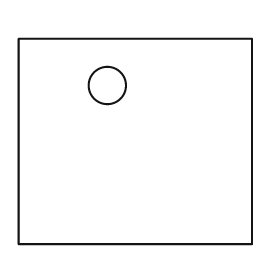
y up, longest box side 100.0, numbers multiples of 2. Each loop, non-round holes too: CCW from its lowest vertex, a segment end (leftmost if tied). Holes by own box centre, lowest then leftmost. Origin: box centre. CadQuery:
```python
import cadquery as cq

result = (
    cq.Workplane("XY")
    .moveTo(-50.0, -44.0)
    .lineTo(50.0, -44.0)
    .lineTo(50.0, 44.0)
    .lineTo(-50.0, 44.0)
    .close()
    .moveTo(-12.0, 24.0)
    .circle(8.0)
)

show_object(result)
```